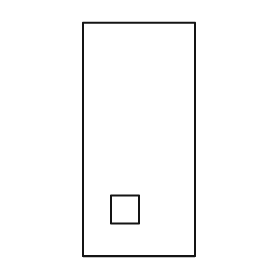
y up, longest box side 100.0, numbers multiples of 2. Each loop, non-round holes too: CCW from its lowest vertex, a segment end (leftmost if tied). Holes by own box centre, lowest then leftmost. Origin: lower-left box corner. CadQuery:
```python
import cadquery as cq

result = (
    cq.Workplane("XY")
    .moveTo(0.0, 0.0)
    .lineTo(48.0, 0.0)
    .lineTo(48.0, 100.0)
    .lineTo(0.0, 100.0)
    .close()
    .moveTo(12.0, 14.0)
    .lineTo(24.0, 14.0)
    .lineTo(24.0, 26.0)
    .lineTo(12.0, 26.0)
    .close()
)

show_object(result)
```